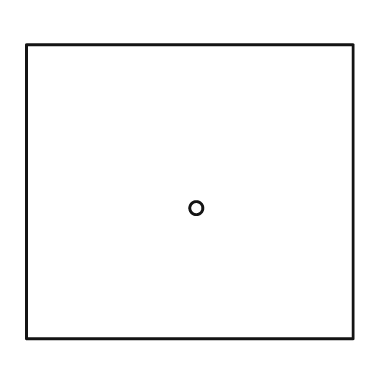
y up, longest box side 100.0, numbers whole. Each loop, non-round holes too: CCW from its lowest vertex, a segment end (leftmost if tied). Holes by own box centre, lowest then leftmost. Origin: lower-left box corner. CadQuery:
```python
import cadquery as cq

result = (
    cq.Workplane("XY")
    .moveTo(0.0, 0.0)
    .lineTo(100.0, 0.0)
    .lineTo(100.0, 90.0)
    .lineTo(0.0, 90.0)
    .close()
    .moveTo(52.0, 40.0)
    .circle(2.0)
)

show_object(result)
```